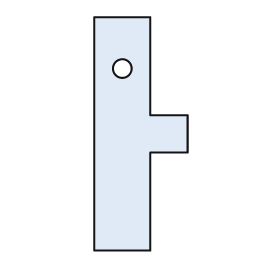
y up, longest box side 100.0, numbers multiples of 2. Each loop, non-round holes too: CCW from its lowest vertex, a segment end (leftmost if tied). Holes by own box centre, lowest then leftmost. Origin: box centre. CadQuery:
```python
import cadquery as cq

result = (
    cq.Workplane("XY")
    .moveTo(-20.0, -50.0)
    .lineTo(4.0, -50.0)
    .lineTo(4.0, -8.0)
    .lineTo(20.0, -8.0)
    .lineTo(20.0, 8.0)
    .lineTo(4.0, 8.0)
    .lineTo(4.0, 50.0)
    .lineTo(-20.0, 50.0)
    .close()
    .moveTo(-8.0, 28.0)
    .circle(4.0)
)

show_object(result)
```